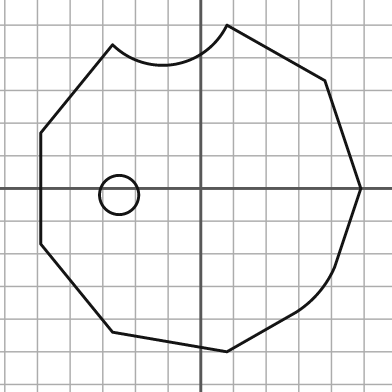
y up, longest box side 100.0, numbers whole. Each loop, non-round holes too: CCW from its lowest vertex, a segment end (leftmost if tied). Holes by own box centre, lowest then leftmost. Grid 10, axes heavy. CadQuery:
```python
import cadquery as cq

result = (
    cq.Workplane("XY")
    .moveTo(8.0, -50.0)
    .lineTo(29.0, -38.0)
    .threePointArc((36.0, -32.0), (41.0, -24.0))
    .lineTo(49.0, 0.0)
    .lineTo(38.0, 33.0)
    .lineTo(8.0, 50.0)
    .threePointArc((-8.0, 38.0), (-27.0, 44.0))
    .lineTo(-49.0, 17.0)
    .lineTo(-49.0, -17.0)
    .lineTo(-27.0, -44.0)
    .close()
    .moveTo(-25.0, -2.0)
    .circle(6.0)
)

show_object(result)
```